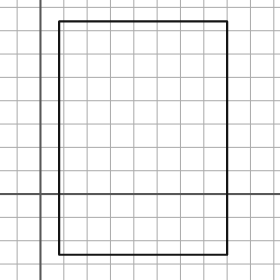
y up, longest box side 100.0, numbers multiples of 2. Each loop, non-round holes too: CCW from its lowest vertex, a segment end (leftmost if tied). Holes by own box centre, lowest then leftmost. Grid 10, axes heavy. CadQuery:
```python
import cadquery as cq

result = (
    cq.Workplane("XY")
    .moveTo(8.0, -26.0)
    .lineTo(80.0, -26.0)
    .lineTo(80.0, 74.0)
    .lineTo(8.0, 74.0)
    .close()
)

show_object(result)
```